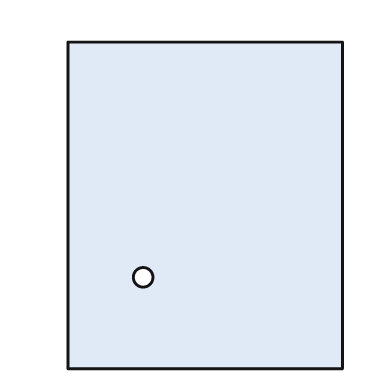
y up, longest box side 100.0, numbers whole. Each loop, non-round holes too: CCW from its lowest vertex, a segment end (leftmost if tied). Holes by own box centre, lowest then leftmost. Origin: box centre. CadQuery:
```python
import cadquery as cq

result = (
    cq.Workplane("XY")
    .moveTo(-42.0, -50.0)
    .lineTo(42.0, -50.0)
    .lineTo(42.0, 50.0)
    .lineTo(-42.0, 50.0)
    .close()
    .moveTo(-19.0, -22.0)
    .circle(3.0)
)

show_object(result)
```